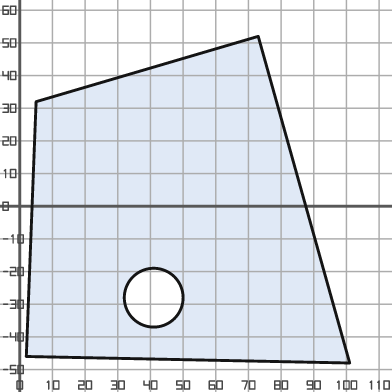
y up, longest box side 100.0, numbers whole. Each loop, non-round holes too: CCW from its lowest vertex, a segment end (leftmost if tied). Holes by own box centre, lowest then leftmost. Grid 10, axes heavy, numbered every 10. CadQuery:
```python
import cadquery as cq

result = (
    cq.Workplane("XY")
    .moveTo(101.0, -48.0)
    .lineTo(73.0, 52.0)
    .lineTo(5.0, 32.0)
    .lineTo(2.0, -46.0)
    .close()
    .moveTo(41.0, -28.0)
    .circle(9.0)
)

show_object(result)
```